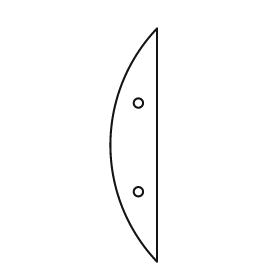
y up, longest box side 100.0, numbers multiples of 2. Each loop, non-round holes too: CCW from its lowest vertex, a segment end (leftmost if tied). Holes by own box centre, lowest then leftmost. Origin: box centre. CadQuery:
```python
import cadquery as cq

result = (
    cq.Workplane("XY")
    .moveTo(10.0, -50.0)
    .lineTo(10.0, 50.0)
    .threePointArc((-10.0, 0.0), (10.0, -50.0))
    .close()
    .moveTo(2.0, -20.0)
    .circle(2.0)
    .moveTo(2.0, 18.0)
    .circle(2.0)
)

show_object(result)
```